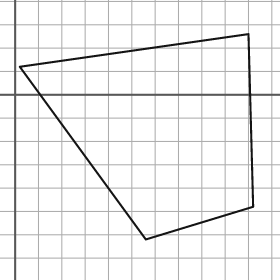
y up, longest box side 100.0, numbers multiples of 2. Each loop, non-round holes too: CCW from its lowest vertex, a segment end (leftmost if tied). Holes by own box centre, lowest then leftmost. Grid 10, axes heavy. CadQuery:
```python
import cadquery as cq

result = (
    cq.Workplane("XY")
    .moveTo(56.0, -62.0)
    .lineTo(102.0, -48.0)
    .lineTo(100.0, 26.0)
    .lineTo(2.0, 12.0)
    .close()
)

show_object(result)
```